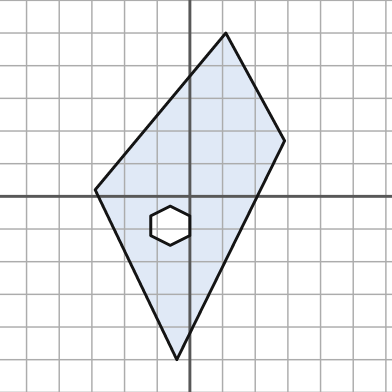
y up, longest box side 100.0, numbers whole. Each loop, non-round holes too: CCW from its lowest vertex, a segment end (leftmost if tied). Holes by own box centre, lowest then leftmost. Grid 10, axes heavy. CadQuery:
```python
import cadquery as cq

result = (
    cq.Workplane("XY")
    .moveTo(-4.0, -50.0)
    .lineTo(29.0, 17.0)
    .lineTo(11.0, 50.0)
    .lineTo(-29.0, 2.0)
    .close()
    .moveTo(-6.0, -15.0)
    .lineTo(0.0, -12.0)
    .lineTo(0.0, -6.0)
    .lineTo(-6.0, -3.0)
    .lineTo(-12.0, -6.0)
    .lineTo(-12.0, -12.0)
    .close()
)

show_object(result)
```